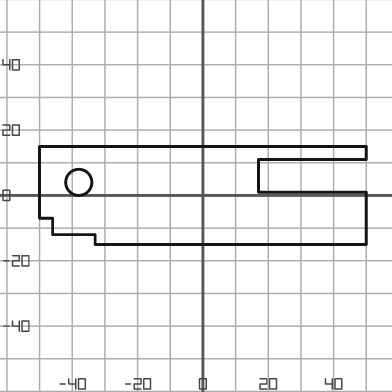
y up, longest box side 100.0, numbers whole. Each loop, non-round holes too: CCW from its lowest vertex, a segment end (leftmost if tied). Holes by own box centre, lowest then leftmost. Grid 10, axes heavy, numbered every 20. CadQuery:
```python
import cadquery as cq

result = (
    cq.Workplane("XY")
    .moveTo(-33.0, -15.0)
    .lineTo(50.0, -15.0)
    .lineTo(50.0, 1.0)
    .lineTo(17.0, 1.0)
    .lineTo(17.0, 11.0)
    .lineTo(50.0, 11.0)
    .lineTo(50.0, 15.0)
    .lineTo(-50.0, 15.0)
    .lineTo(-50.0, -7.0)
    .lineTo(-46.0, -7.0)
    .lineTo(-46.0, -12.0)
    .lineTo(-33.0, -12.0)
    .close()
    .moveTo(-38.0, 4.0)
    .circle(4.0)
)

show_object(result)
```